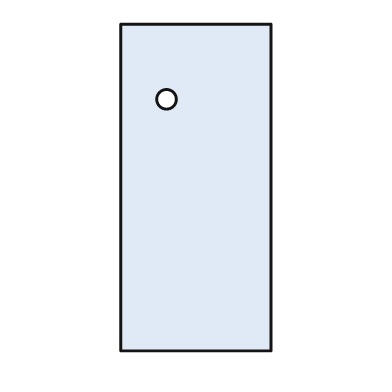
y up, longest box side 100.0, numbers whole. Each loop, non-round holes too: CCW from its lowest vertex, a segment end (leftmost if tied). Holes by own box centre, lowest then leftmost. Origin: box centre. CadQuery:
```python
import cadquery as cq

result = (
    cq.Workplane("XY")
    .moveTo(-23.0, -50.0)
    .lineTo(23.0, -50.0)
    .lineTo(23.0, 50.0)
    .lineTo(-23.0, 50.0)
    .close()
    .moveTo(-9.0, 27.0)
    .circle(3.0)
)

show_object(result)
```